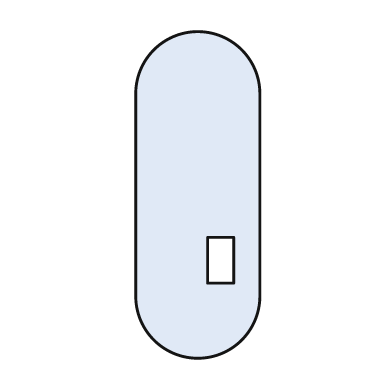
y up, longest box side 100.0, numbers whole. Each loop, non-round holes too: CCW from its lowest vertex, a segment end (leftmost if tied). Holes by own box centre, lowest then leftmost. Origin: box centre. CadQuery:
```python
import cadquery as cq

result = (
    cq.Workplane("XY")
    .moveTo(-19.0, -31.0)
    .threePointArc((0.0, -50.0), (19.0, -31.0))
    .lineTo(19.0, 31.0)
    .threePointArc((0.0, 50.0), (-19.0, 31.0))
    .close()
    .moveTo(3.0, -27.0)
    .lineTo(11.0, -27.0)
    .lineTo(11.0, -13.0)
    .lineTo(3.0, -13.0)
    .close()
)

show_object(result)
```